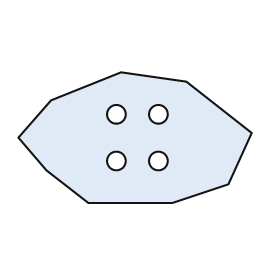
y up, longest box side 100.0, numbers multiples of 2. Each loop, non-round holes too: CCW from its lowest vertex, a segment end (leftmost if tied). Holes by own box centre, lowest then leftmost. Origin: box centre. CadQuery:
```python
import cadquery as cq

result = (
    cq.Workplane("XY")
    .moveTo(-20.0, -28.0)
    .lineTo(16.0, -28.0)
    .lineTo(40.0, -20.0)
    .lineTo(50.0, 2.0)
    .lineTo(22.0, 24.0)
    .lineTo(-6.0, 28.0)
    .lineTo(-36.0, 16.0)
    .lineTo(-50.0, 0.0)
    .lineTo(-38.0, -14.0)
    .close()
    .moveTo(-8.0, -10.0)
    .circle(4.0)
    .moveTo(10.0, -10.0)
    .circle(4.0)
    .moveTo(-8.0, 10.0)
    .circle(4.0)
    .moveTo(10.0, 10.0)
    .circle(4.0)
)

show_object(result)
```